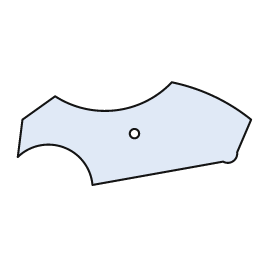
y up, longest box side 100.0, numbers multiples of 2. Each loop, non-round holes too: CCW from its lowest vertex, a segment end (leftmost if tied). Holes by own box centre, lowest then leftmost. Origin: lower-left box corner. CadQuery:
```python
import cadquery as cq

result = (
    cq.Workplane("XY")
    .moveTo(32.0, 0.0)
    .lineTo(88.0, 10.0)
    .threePointArc((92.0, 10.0), (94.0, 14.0))
    .lineTo(100.0, 28.0)
    .threePointArc((84.0, 38.0), (66.0, 44.0))
    .threePointArc((42.0, 32.0), (16.0, 38.0))
    .lineTo(2.0, 28.0)
    .lineTo(0.0, 12.0)
    .threePointArc((20.0, 16.0), (32.0, 0.0))
    .close()
    .moveTo(50.0, 22.0)
    .circle(2.0)
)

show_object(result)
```